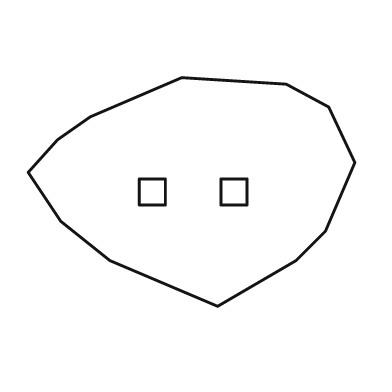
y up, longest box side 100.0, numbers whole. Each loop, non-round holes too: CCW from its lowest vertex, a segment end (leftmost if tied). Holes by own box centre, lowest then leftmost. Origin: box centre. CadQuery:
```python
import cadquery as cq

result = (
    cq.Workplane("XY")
    .moveTo(8.0, -35.0)
    .lineTo(32.0, -21.0)
    .lineTo(41.0, -12.0)
    .lineTo(50.0, 9.0)
    .lineTo(42.0, 26.0)
    .lineTo(29.0, 33.0)
    .lineTo(-3.0, 35.0)
    .lineTo(-31.0, 23.0)
    .lineTo(-41.0, 16.0)
    .lineTo(-50.0, 6.0)
    .lineTo(-40.0, -9.0)
    .lineTo(-25.0, -21.0)
    .close()
    .moveTo(-16.0, -4.0)
    .lineTo(-8.0, -4.0)
    .lineTo(-8.0, 4.0)
    .lineTo(-16.0, 4.0)
    .close()
    .moveTo(9.0, -4.0)
    .lineTo(17.0, -4.0)
    .lineTo(17.0, 4.0)
    .lineTo(9.0, 4.0)
    .close()
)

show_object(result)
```